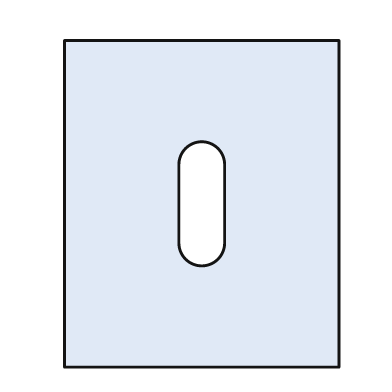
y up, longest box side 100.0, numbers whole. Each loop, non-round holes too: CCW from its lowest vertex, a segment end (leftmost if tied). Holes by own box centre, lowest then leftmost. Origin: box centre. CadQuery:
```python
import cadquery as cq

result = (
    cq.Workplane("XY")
    .moveTo(-42.0, -50.0)
    .lineTo(42.0, -50.0)
    .lineTo(42.0, 50.0)
    .lineTo(-42.0, 50.0)
    .close()
    .moveTo(-7.0, -12.0)
    .threePointArc((0.0, -19.0), (7.0, -12.0))
    .lineTo(7.0, 12.0)
    .threePointArc((0.0, 19.0), (-7.0, 12.0))
    .close()
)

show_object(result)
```